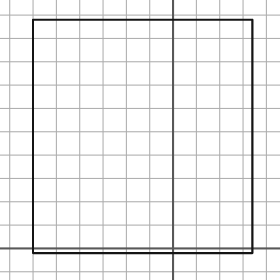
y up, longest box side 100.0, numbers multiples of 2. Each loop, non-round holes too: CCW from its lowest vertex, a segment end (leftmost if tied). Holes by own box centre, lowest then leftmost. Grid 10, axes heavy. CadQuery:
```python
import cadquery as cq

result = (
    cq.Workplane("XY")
    .moveTo(-60.0, -2.0)
    .lineTo(34.0, -2.0)
    .lineTo(34.0, 98.0)
    .lineTo(-60.0, 98.0)
    .close()
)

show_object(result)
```